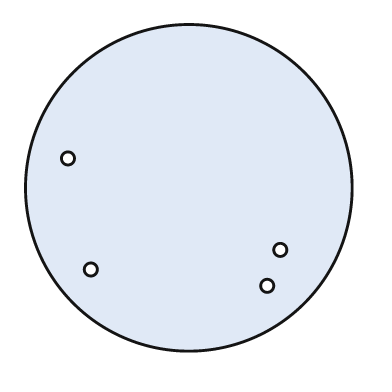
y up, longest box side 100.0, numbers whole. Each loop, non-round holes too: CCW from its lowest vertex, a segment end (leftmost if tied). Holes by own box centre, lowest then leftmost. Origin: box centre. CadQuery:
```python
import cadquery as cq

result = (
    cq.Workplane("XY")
    .moveTo(0.0, 0.0)
    .circle(50.0)
    .moveTo(24.0, -30.0)
    .circle(2.0)
    .moveTo(-30.0, -25.0)
    .circle(2.0)
    .moveTo(28.0, -19.0)
    .circle(2.0)
    .moveTo(-37.0, 9.0)
    .circle(2.0)
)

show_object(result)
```